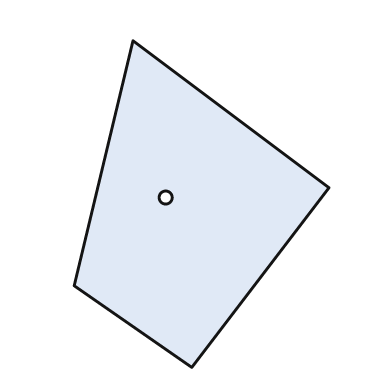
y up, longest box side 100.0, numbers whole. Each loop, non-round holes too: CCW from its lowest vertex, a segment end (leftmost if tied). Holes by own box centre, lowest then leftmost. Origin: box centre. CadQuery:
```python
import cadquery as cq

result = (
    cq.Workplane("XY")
    .moveTo(-3.0, -50.0)
    .lineTo(39.0, 5.0)
    .lineTo(-21.0, 50.0)
    .lineTo(-39.0, -25.0)
    .close()
    .moveTo(-11.0, 2.0)
    .circle(2.0)
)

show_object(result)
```